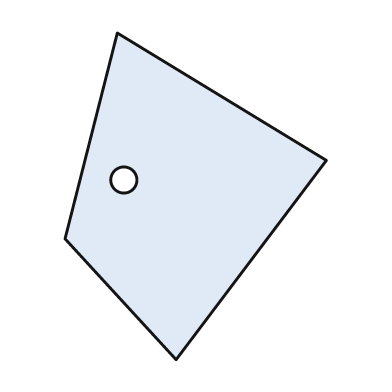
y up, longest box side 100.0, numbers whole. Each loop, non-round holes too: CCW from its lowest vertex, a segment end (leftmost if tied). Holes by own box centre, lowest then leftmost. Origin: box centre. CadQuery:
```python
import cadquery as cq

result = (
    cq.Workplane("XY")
    .moveTo(-6.0, -50.0)
    .lineTo(40.0, 11.0)
    .lineTo(-24.0, 50.0)
    .lineTo(-40.0, -13.0)
    .close()
    .moveTo(-22.0, 5.0)
    .circle(4.0)
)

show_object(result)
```